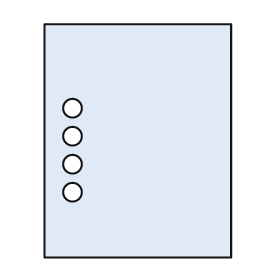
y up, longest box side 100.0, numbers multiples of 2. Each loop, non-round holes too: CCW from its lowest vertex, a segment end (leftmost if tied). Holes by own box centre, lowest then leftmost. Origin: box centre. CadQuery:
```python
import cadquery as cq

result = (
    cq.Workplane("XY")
    .moveTo(-40.0, -50.0)
    .lineTo(40.0, -50.0)
    .lineTo(40.0, 50.0)
    .lineTo(-40.0, 50.0)
    .close()
    .moveTo(-28.0, -22.0)
    .circle(4.0)
    .moveTo(-28.0, -10.0)
    .circle(4.0)
    .moveTo(-28.0, 2.0)
    .circle(4.0)
    .moveTo(-28.0, 14.0)
    .circle(4.0)
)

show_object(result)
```